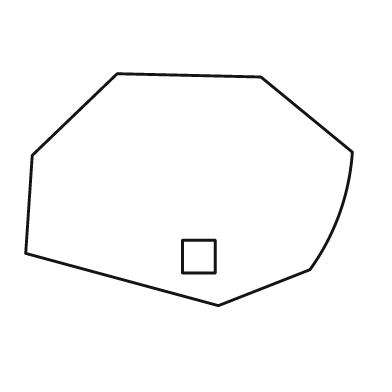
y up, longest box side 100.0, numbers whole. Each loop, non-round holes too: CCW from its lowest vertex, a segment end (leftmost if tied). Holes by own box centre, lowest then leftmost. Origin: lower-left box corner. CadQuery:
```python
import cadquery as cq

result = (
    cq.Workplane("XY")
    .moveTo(59.0, 0.0)
    .lineTo(87.0, 11.0)
    .threePointArc((96.0, 28.0), (100.0, 47.0))
    .lineTo(72.0, 70.0)
    .lineTo(28.0, 71.0)
    .lineTo(2.0, 46.0)
    .lineTo(0.0, 16.0)
    .close()
    .moveTo(48.0, 10.0)
    .lineTo(58.0, 10.0)
    .lineTo(58.0, 20.0)
    .lineTo(48.0, 20.0)
    .close()
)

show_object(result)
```